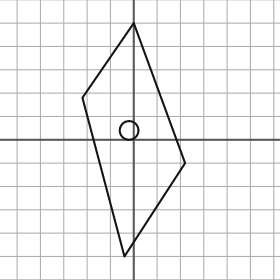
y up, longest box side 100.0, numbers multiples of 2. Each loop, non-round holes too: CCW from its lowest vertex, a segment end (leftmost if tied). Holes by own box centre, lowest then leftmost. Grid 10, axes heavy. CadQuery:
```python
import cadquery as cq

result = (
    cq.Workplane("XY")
    .moveTo(-4.0, -50.0)
    .lineTo(22.0, -10.0)
    .lineTo(0.0, 50.0)
    .lineTo(-22.0, 18.0)
    .close()
    .moveTo(-2.0, 4.0)
    .circle(4.0)
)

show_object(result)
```